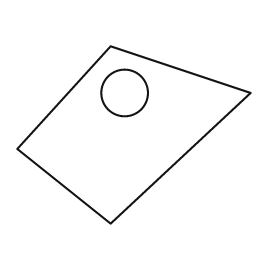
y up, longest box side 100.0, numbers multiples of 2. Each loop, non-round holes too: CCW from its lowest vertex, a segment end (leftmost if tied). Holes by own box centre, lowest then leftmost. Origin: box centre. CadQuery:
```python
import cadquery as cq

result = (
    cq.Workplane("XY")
    .moveTo(-10.0, -38.0)
    .lineTo(50.0, 18.0)
    .lineTo(-10.0, 38.0)
    .lineTo(-50.0, -6.0)
    .close()
    .moveTo(-4.0, 18.0)
    .circle(10.0)
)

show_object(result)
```